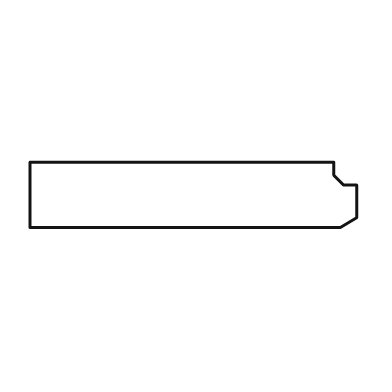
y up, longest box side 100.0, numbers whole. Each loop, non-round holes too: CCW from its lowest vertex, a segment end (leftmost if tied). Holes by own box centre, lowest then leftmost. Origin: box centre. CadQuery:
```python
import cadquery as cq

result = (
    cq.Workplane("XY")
    .moveTo(-50.0, -10.0)
    .lineTo(45.0, -10.0)
    .lineTo(50.0, -7.0)
    .lineTo(50.0, 3.0)
    .lineTo(46.0, 3.0)
    .lineTo(43.0, 6.0)
    .lineTo(43.0, 10.0)
    .lineTo(-50.0, 10.0)
    .close()
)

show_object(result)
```